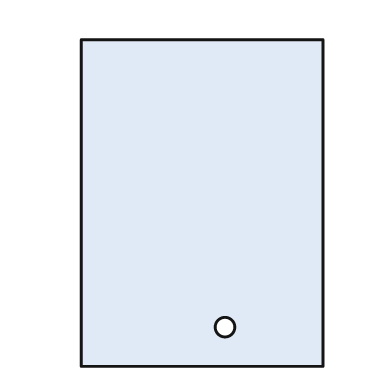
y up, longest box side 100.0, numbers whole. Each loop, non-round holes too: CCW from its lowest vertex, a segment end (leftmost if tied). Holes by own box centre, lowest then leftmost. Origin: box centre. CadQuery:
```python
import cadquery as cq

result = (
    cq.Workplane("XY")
    .moveTo(-37.0, -50.0)
    .lineTo(37.0, -50.0)
    .lineTo(37.0, 50.0)
    .lineTo(-37.0, 50.0)
    .close()
    .moveTo(7.0, -38.0)
    .circle(3.0)
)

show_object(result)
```